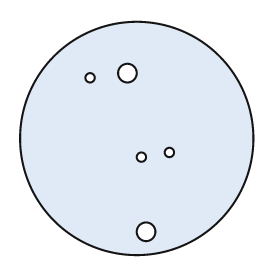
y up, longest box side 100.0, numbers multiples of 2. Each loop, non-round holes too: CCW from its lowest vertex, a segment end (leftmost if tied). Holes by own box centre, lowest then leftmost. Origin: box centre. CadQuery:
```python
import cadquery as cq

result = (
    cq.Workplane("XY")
    .moveTo(0.0, 0.0)
    .circle(50.0)
    .moveTo(4.0, -40.0)
    .circle(4.0)
    .moveTo(2.0, -8.0)
    .circle(2.0)
    .moveTo(14.0, -6.0)
    .circle(2.0)
    .moveTo(-20.0, 26.0)
    .circle(2.0)
    .moveTo(-4.0, 28.0)
    .circle(4.0)
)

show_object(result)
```